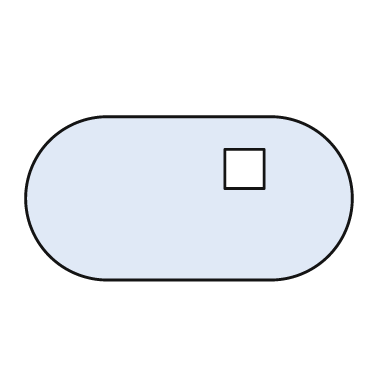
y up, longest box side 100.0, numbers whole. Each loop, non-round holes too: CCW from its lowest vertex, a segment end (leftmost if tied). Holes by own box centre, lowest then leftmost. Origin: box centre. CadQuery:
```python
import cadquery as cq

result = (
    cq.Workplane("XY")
    .moveTo(-25.0, -25.0)
    .lineTo(25.0, -25.0)
    .threePointArc((50.0, 0.0), (25.0, 25.0))
    .lineTo(-25.0, 25.0)
    .threePointArc((-50.0, 0.0), (-25.0, -25.0))
    .close()
    .moveTo(11.0, 3.0)
    .lineTo(23.0, 3.0)
    .lineTo(23.0, 15.0)
    .lineTo(11.0, 15.0)
    .close()
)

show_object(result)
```